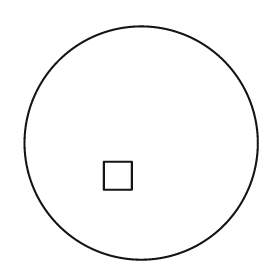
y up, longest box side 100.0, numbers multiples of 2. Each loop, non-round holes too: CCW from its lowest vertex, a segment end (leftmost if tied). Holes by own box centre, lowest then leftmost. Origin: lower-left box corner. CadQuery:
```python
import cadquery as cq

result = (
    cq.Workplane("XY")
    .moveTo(50.0, 50.0)
    .circle(50.0)
    .moveTo(34.0, 30.0)
    .lineTo(46.0, 30.0)
    .lineTo(46.0, 42.0)
    .lineTo(34.0, 42.0)
    .close()
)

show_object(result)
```